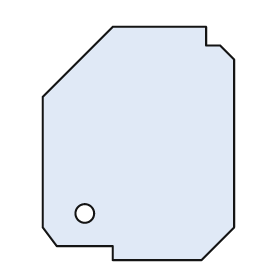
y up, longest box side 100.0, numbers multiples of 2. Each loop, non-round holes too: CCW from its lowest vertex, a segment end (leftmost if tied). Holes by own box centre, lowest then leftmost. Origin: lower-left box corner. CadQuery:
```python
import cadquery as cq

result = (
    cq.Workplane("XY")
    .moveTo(30.0, 0.0)
    .lineTo(68.0, 0.0)
    .lineTo(82.0, 14.0)
    .lineTo(82.0, 86.0)
    .lineTo(76.0, 92.0)
    .lineTo(70.0, 92.0)
    .lineTo(70.0, 100.0)
    .lineTo(30.0, 100.0)
    .lineTo(0.0, 70.0)
    .lineTo(0.0, 14.0)
    .lineTo(6.0, 6.0)
    .lineTo(30.0, 6.0)
    .close()
    .moveTo(18.0, 20.0)
    .circle(4.0)
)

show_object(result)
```